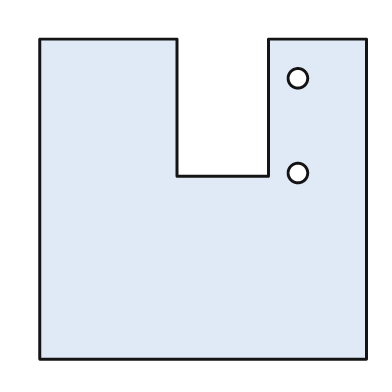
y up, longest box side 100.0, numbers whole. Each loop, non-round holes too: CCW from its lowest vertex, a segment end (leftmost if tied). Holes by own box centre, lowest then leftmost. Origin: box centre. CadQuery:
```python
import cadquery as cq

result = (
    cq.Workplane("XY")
    .moveTo(-50.0, -49.0)
    .lineTo(50.0, -49.0)
    .lineTo(50.0, 49.0)
    .lineTo(20.0, 49.0)
    .lineTo(20.0, 7.0)
    .lineTo(-8.0, 7.0)
    .lineTo(-8.0, 49.0)
    .lineTo(-50.0, 49.0)
    .close()
    .moveTo(29.0, 8.0)
    .circle(3.0)
    .moveTo(29.0, 37.0)
    .circle(3.0)
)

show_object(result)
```